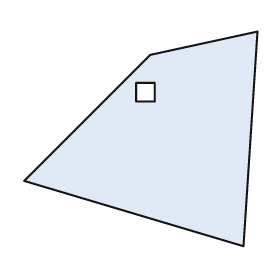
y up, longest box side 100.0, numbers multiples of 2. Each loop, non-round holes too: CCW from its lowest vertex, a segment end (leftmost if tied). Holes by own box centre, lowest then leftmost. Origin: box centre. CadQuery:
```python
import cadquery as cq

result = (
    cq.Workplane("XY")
    .moveTo(44.0, -46.0)
    .lineTo(50.0, 46.0)
    .lineTo(4.0, 36.0)
    .lineTo(-50.0, -18.0)
    .close()
    .moveTo(-2.0, 16.0)
    .lineTo(6.0, 16.0)
    .lineTo(6.0, 24.0)
    .lineTo(-2.0, 24.0)
    .close()
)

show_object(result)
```